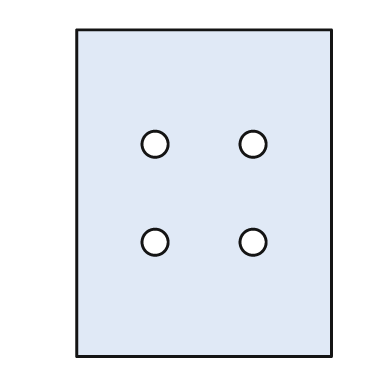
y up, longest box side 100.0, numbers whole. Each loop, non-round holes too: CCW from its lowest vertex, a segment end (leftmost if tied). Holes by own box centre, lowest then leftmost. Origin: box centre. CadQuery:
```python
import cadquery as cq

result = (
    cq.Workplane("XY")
    .moveTo(-39.0, -50.0)
    .lineTo(39.0, -50.0)
    .lineTo(39.0, 50.0)
    .lineTo(-39.0, 50.0)
    .close()
    .moveTo(-15.0, -15.0)
    .circle(4.0)
    .moveTo(15.0, -15.0)
    .circle(4.0)
    .moveTo(-15.0, 15.0)
    .circle(4.0)
    .moveTo(15.0, 15.0)
    .circle(4.0)
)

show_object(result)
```